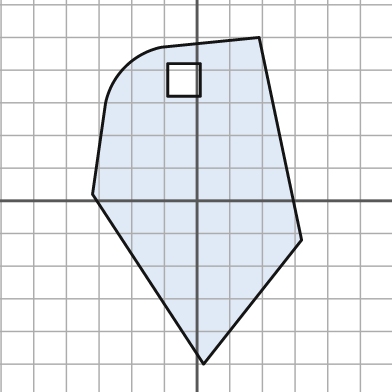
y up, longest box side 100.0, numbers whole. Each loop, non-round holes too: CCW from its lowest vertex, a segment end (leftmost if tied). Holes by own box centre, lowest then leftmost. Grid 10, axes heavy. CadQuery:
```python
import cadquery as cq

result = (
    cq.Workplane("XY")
    .moveTo(2.0, -50.0)
    .lineTo(32.0, -12.0)
    .lineTo(19.0, 50.0)
    .lineTo(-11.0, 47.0)
    .threePointArc((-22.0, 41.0), (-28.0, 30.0))
    .lineTo(-32.0, 2.0)
    .close()
    .moveTo(-9.0, 32.0)
    .lineTo(1.0, 32.0)
    .lineTo(1.0, 42.0)
    .lineTo(-9.0, 42.0)
    .close()
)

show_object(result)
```